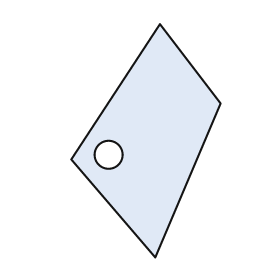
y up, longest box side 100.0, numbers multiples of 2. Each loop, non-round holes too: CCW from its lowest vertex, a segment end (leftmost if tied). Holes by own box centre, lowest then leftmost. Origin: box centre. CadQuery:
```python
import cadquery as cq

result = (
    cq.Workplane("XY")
    .moveTo(4.0, -50.0)
    .lineTo(32.0, 16.0)
    .lineTo(6.0, 50.0)
    .lineTo(-32.0, -8.0)
    .close()
    .moveTo(-16.0, -6.0)
    .circle(6.0)
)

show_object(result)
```